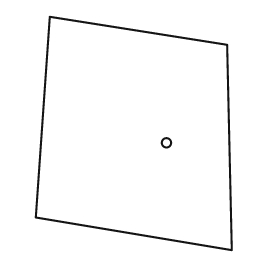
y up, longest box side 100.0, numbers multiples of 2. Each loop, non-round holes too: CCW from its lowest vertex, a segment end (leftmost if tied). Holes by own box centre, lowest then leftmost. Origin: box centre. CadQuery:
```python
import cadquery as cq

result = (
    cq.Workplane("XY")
    .moveTo(42.0, -50.0)
    .lineTo(40.0, 38.0)
    .lineTo(-36.0, 50.0)
    .lineTo(-42.0, -36.0)
    .close()
    .moveTo(14.0, -4.0)
    .circle(2.0)
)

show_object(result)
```